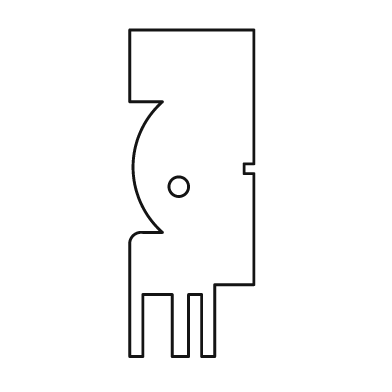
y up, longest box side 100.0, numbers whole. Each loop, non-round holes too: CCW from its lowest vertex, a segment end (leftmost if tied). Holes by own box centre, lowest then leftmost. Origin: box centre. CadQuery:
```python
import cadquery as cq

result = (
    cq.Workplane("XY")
    .moveTo(-19.0, -50.0)
    .lineTo(-15.0, -50.0)
    .lineTo(-15.0, -31.0)
    .lineTo(-6.0, -31.0)
    .lineTo(-6.0, -50.0)
    .lineTo(-1.0, -50.0)
    .lineTo(-1.0, -31.0)
    .lineTo(3.0, -31.0)
    .lineTo(3.0, -50.0)
    .lineTo(7.0, -50.0)
    .lineTo(7.0, -28.0)
    .lineTo(19.0, -28.0)
    .lineTo(19.0, 6.0)
    .lineTo(16.0, 6.0)
    .lineTo(16.0, 9.0)
    .lineTo(19.0, 9.0)
    .lineTo(19.0, 50.0)
    .lineTo(-19.0, 50.0)
    .lineTo(-19.0, 28.0)
    .lineTo(-9.0, 28.0)
    .threePointArc((-18.0, 8.0), (-9.0, -12.0))
    .lineTo(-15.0, -12.0)
    .threePointArc((-18.0, -13.0), (-19.0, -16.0))
    .close()
    .moveTo(-4.0, 2.0)
    .circle(3.0)
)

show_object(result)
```